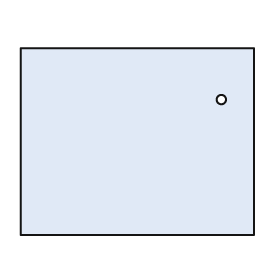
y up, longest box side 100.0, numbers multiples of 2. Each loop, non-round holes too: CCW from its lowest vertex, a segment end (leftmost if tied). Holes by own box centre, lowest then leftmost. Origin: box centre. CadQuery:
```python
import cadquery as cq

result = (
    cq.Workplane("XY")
    .moveTo(-50.0, -40.0)
    .lineTo(50.0, -40.0)
    .lineTo(50.0, 40.0)
    .lineTo(-50.0, 40.0)
    .close()
    .moveTo(36.0, 18.0)
    .circle(2.0)
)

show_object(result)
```